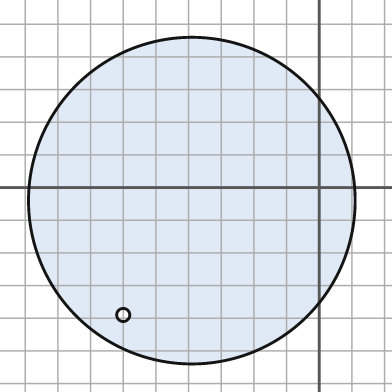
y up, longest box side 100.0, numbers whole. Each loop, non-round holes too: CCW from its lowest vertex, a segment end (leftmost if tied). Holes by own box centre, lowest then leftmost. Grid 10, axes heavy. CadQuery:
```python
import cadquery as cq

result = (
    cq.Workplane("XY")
    .moveTo(-39.0, -4.0)
    .circle(50.0)
    .moveTo(-60.0, -39.0)
    .circle(2.0)
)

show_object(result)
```